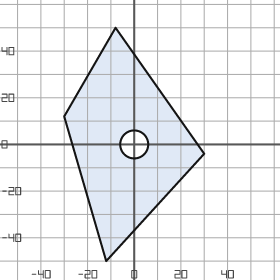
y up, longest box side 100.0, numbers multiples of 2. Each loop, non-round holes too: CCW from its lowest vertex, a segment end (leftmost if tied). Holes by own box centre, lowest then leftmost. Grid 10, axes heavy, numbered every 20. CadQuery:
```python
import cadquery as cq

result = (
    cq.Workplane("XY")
    .moveTo(-12.0, -50.0)
    .lineTo(30.0, -4.0)
    .lineTo(-8.0, 50.0)
    .lineTo(-30.0, 12.0)
    .close()
    .moveTo(0.0, 0.0)
    .circle(6.0)
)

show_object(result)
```